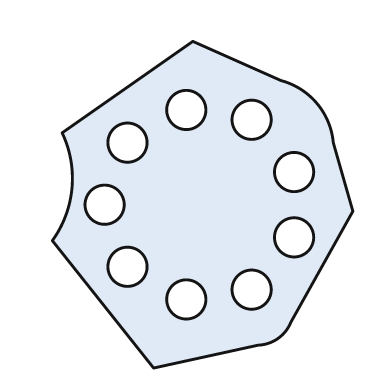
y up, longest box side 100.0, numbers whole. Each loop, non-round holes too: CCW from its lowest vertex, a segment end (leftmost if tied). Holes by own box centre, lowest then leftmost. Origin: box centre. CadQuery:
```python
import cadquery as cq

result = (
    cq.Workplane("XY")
    .moveTo(-15.0, -50.0)
    .lineTo(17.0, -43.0)
    .threePointArc((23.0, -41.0), (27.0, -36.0))
    .lineTo(46.0, -2.0)
    .lineTo(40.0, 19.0)
    .threePointArc((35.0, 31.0), (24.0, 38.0))
    .lineTo(-3.0, 50.0)
    .lineTo(-43.0, 22.0)
    .threePointArc((-40.0, 5.0), (-46.0, -11.0))
    .close()
    .moveTo(-5.0, -29.0)
    .circle(6.0)
    .moveTo(15.0, -26.0)
    .circle(6.0)
    .moveTo(-23.0, -19.0)
    .circle(6.0)
    .moveTo(28.0, -10.0)
    .circle(6.0)
    .moveTo(-30.0, 0.0)
    .circle(6.0)
    .moveTo(28.0, 10.0)
    .circle(6.0)
    .moveTo(-23.0, 19.0)
    .circle(6.0)
    .moveTo(15.0, 26.0)
    .circle(6.0)
    .moveTo(-5.0, 29.0)
    .circle(6.0)
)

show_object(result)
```